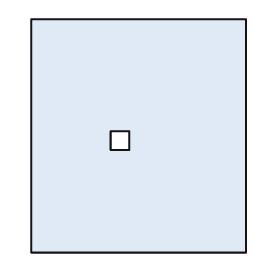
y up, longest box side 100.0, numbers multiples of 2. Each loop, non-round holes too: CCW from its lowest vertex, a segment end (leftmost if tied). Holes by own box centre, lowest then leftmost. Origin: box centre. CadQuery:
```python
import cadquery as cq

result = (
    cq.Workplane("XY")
    .moveTo(-46.0, -50.0)
    .lineTo(46.0, -50.0)
    .lineTo(46.0, 50.0)
    .lineTo(-46.0, 50.0)
    .close()
    .moveTo(-12.0, -6.0)
    .lineTo(-4.0, -6.0)
    .lineTo(-4.0, 2.0)
    .lineTo(-12.0, 2.0)
    .close()
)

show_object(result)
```